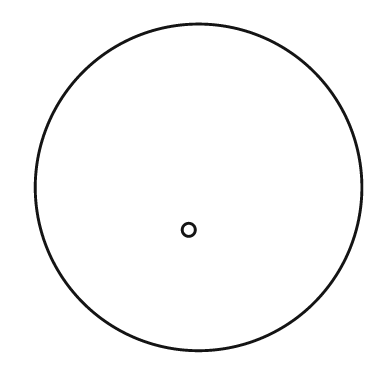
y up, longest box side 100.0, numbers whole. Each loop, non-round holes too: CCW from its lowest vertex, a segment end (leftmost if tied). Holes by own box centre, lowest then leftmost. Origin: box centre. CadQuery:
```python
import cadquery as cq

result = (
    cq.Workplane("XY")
    .moveTo(0.0, 0.0)
    .circle(50.0)
    .moveTo(-3.0, -13.0)
    .circle(2.0)
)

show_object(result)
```